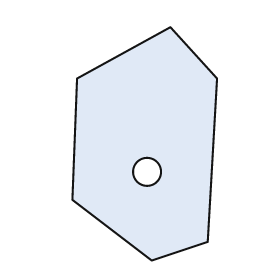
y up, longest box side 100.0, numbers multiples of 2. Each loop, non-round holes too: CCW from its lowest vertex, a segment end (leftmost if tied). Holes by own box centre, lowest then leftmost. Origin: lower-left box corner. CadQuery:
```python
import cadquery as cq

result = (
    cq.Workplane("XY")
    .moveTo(34.0, 0.0)
    .lineTo(58.0, 8.0)
    .lineTo(62.0, 78.0)
    .lineTo(42.0, 100.0)
    .lineTo(2.0, 78.0)
    .lineTo(0.0, 26.0)
    .close()
    .moveTo(32.0, 38.0)
    .circle(6.0)
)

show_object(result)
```